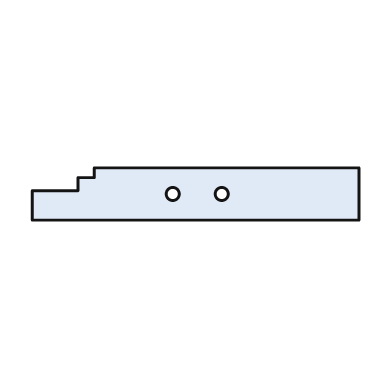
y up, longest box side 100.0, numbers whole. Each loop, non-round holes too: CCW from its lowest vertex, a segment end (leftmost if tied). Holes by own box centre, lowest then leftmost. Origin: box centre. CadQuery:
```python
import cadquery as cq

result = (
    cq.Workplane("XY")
    .moveTo(-50.0, -8.0)
    .lineTo(50.0, -8.0)
    .lineTo(50.0, 8.0)
    .lineTo(-31.0, 8.0)
    .lineTo(-31.0, 5.0)
    .lineTo(-36.0, 5.0)
    .lineTo(-36.0, 1.0)
    .lineTo(-50.0, 1.0)
    .close()
    .moveTo(-7.0, 0.0)
    .circle(2.0)
    .moveTo(8.0, 0.0)
    .circle(2.0)
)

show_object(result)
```